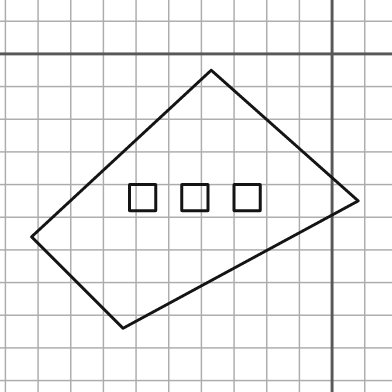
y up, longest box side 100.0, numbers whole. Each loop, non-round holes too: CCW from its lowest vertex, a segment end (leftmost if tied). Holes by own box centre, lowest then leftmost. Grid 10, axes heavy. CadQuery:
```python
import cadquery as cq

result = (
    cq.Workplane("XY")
    .moveTo(-64.0, -84.0)
    .lineTo(8.0, -45.0)
    .lineTo(-37.0, -5.0)
    .lineTo(-92.0, -56.0)
    .close()
    .moveTo(-62.0, -48.0)
    .lineTo(-54.0, -48.0)
    .lineTo(-54.0, -40.0)
    .lineTo(-62.0, -40.0)
    .close()
    .moveTo(-46.0, -48.0)
    .lineTo(-38.0, -48.0)
    .lineTo(-38.0, -40.0)
    .lineTo(-46.0, -40.0)
    .close()
    .moveTo(-30.0, -48.0)
    .lineTo(-22.0, -48.0)
    .lineTo(-22.0, -40.0)
    .lineTo(-30.0, -40.0)
    .close()
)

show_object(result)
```